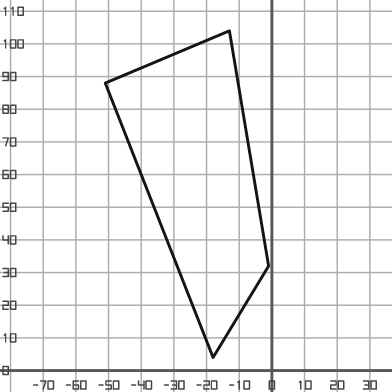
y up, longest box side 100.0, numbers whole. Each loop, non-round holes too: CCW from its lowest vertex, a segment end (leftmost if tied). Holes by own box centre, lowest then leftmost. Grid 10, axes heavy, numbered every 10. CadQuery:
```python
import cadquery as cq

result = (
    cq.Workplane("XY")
    .moveTo(-18.0, 4.0)
    .lineTo(-1.0, 32.0)
    .lineTo(-13.0, 104.0)
    .lineTo(-51.0, 88.0)
    .close()
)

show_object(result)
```